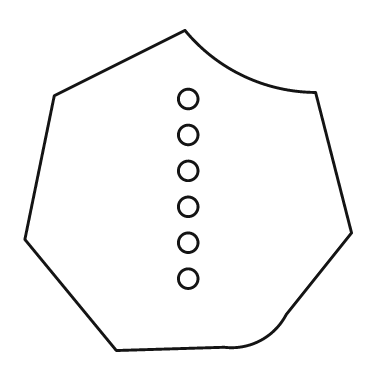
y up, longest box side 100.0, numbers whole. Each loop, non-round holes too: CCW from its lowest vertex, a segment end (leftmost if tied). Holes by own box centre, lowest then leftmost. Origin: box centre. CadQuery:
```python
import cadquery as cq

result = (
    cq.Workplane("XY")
    .moveTo(-22.0, -49.0)
    .lineTo(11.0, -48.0)
    .threePointArc((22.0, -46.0), (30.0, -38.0))
    .lineTo(50.0, -13.0)
    .lineTo(39.0, 30.0)
    .threePointArc((17.0, 35.0), (-1.0, 49.0))
    .lineTo(-41.0, 29.0)
    .lineTo(-50.0, -15.0)
    .close()
    .moveTo(0.0, -27.0)
    .circle(3.0)
    .moveTo(0.0, -16.0)
    .circle(3.0)
    .moveTo(0.0, -5.0)
    .circle(3.0)
    .moveTo(0.0, 6.0)
    .circle(3.0)
    .moveTo(0.0, 17.0)
    .circle(3.0)
    .moveTo(0.0, 28.0)
    .circle(3.0)
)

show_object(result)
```